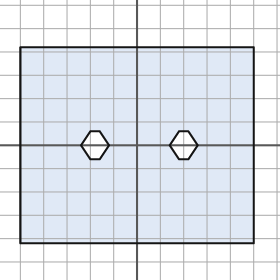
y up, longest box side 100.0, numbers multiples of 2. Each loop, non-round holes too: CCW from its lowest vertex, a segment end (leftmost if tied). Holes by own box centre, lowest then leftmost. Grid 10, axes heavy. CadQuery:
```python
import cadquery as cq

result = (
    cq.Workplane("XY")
    .moveTo(-50.0, -42.0)
    .lineTo(50.0, -42.0)
    .lineTo(50.0, 42.0)
    .lineTo(-50.0, 42.0)
    .close()
    .moveTo(-20.0, -6.0)
    .lineTo(-16.0, -6.0)
    .lineTo(-12.0, 0.0)
    .lineTo(-16.0, 6.0)
    .lineTo(-20.0, 6.0)
    .lineTo(-24.0, 0.0)
    .close()
    .moveTo(18.0, -6.0)
    .lineTo(22.0, -6.0)
    .lineTo(26.0, 0.0)
    .lineTo(22.0, 6.0)
    .lineTo(18.0, 6.0)
    .lineTo(14.0, 0.0)
    .close()
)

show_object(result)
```